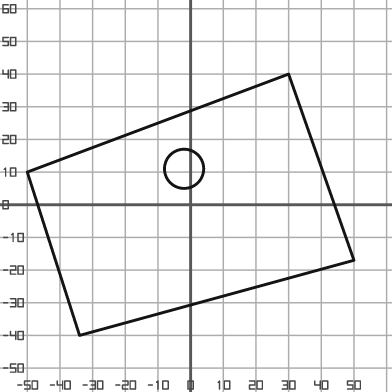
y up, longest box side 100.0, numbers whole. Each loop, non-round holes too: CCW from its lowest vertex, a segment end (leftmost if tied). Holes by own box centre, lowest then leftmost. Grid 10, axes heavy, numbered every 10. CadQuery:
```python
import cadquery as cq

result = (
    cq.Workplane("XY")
    .moveTo(-34.0, -40.0)
    .lineTo(50.0, -17.0)
    .lineTo(30.0, 40.0)
    .lineTo(-50.0, 10.0)
    .close()
    .moveTo(-2.0, 11.0)
    .circle(6.0)
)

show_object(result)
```